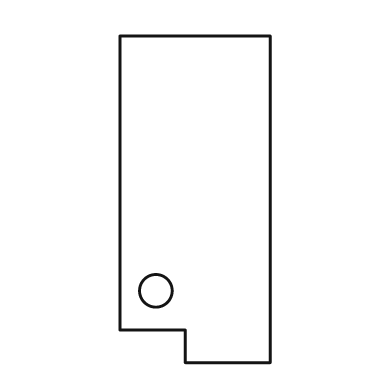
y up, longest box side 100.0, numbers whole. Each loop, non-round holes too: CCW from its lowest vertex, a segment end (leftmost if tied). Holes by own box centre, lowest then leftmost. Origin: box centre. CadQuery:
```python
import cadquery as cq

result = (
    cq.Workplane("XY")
    .moveTo(-3.0, -50.0)
    .lineTo(23.0, -50.0)
    .lineTo(23.0, 50.0)
    .lineTo(-23.0, 50.0)
    .lineTo(-23.0, -40.0)
    .lineTo(-3.0, -40.0)
    .close()
    .moveTo(-12.0, -28.0)
    .circle(5.0)
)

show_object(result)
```